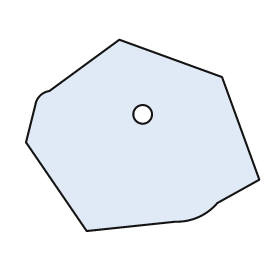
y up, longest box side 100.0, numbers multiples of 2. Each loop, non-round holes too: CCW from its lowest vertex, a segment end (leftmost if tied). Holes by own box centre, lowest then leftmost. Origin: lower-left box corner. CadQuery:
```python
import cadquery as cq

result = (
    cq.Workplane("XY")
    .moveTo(26.0, 0.0)
    .lineTo(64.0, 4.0)
    .threePointArc((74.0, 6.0), (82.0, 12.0))
    .lineTo(100.0, 22.0)
    .lineTo(84.0, 66.0)
    .lineTo(40.0, 82.0)
    .lineTo(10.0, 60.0)
    .threePointArc((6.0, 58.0), (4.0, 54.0))
    .lineTo(0.0, 38.0)
    .close()
    .moveTo(50.0, 50.0)
    .circle(4.0)
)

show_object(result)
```